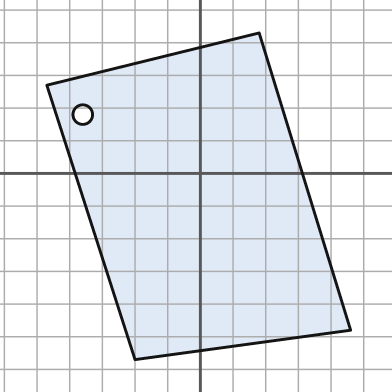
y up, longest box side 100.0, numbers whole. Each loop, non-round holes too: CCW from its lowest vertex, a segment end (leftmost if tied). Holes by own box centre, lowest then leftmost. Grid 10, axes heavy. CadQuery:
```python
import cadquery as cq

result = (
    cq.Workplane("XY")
    .moveTo(-20.0, -57.0)
    .lineTo(46.0, -48.0)
    .lineTo(18.0, 43.0)
    .lineTo(-47.0, 27.0)
    .close()
    .moveTo(-36.0, 18.0)
    .circle(3.0)
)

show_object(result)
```